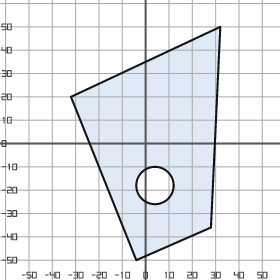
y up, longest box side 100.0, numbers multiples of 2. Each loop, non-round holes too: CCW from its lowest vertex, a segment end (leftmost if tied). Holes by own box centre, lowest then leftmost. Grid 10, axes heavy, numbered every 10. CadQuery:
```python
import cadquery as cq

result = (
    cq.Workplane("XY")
    .moveTo(-4.0, -50.0)
    .lineTo(28.0, -36.0)
    .lineTo(32.0, 50.0)
    .lineTo(-32.0, 20.0)
    .close()
    .moveTo(4.0, -18.0)
    .circle(8.0)
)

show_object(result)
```